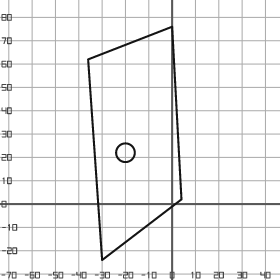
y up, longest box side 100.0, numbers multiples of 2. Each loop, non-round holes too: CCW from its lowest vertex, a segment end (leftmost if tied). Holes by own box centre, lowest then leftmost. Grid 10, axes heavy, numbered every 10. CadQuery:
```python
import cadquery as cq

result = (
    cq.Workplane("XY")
    .moveTo(-30.0, -24.0)
    .lineTo(4.0, 2.0)
    .lineTo(0.0, 76.0)
    .lineTo(-36.0, 62.0)
    .close()
    .moveTo(-20.0, 22.0)
    .circle(4.0)
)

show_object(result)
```